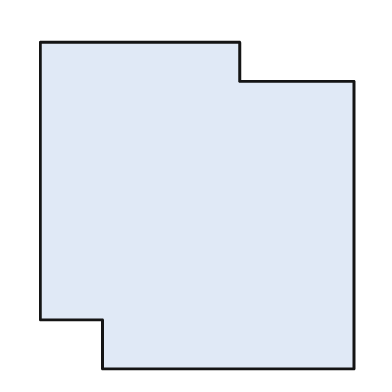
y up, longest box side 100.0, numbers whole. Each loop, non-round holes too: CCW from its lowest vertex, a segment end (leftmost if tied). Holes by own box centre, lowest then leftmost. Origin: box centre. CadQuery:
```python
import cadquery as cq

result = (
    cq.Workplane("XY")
    .moveTo(-29.0, -50.0)
    .lineTo(48.0, -50.0)
    .lineTo(48.0, 38.0)
    .lineTo(13.0, 38.0)
    .lineTo(13.0, 50.0)
    .lineTo(-48.0, 50.0)
    .lineTo(-48.0, -35.0)
    .lineTo(-29.0, -35.0)
    .close()
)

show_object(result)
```